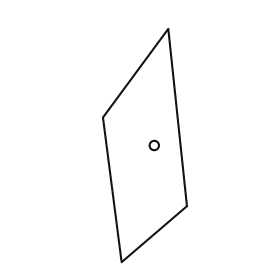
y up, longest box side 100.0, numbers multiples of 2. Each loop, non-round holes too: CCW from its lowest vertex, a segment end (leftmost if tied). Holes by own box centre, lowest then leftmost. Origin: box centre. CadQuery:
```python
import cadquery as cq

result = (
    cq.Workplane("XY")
    .moveTo(-10.0, -50.0)
    .lineTo(18.0, -26.0)
    .lineTo(10.0, 50.0)
    .lineTo(-18.0, 12.0)
    .close()
    .moveTo(4.0, 0.0)
    .circle(2.0)
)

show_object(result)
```